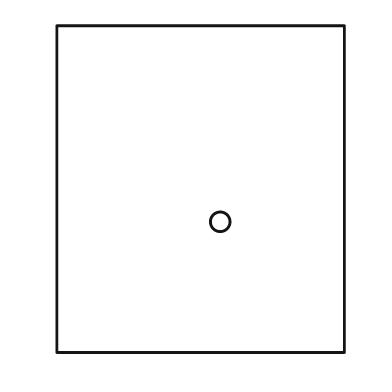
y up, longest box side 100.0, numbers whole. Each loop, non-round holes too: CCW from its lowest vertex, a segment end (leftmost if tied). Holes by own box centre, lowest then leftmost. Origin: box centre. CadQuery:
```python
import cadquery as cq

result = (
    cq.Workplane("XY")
    .moveTo(-44.0, -50.0)
    .lineTo(44.0, -50.0)
    .lineTo(44.0, 50.0)
    .lineTo(-44.0, 50.0)
    .close()
    .moveTo(6.0, -10.0)
    .circle(3.0)
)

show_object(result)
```